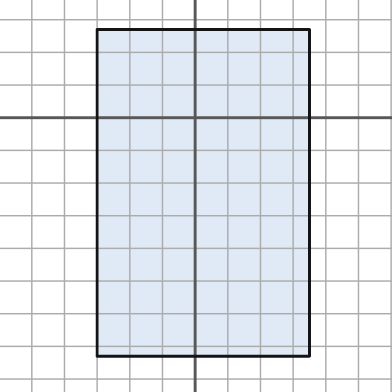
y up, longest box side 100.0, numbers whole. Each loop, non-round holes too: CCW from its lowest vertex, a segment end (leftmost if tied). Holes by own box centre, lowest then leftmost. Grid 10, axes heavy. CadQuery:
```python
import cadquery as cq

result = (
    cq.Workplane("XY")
    .moveTo(-30.0, -73.0)
    .lineTo(35.0, -73.0)
    .lineTo(35.0, 27.0)
    .lineTo(-30.0, 27.0)
    .close()
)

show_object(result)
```